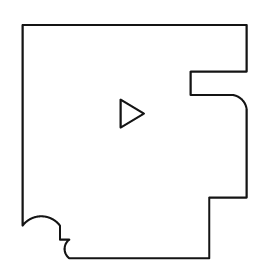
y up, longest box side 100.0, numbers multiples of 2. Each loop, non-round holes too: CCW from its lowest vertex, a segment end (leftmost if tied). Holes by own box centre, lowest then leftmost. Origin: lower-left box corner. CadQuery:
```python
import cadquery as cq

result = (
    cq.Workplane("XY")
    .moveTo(20.0, 0.0)
    .lineTo(80.0, 0.0)
    .lineTo(80.0, 26.0)
    .lineTo(96.0, 26.0)
    .lineTo(96.0, 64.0)
    .threePointArc((94.0, 68.0), (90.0, 70.0))
    .lineTo(72.0, 70.0)
    .lineTo(72.0, 80.0)
    .lineTo(96.0, 80.0)
    .lineTo(96.0, 100.0)
    .lineTo(0.0, 100.0)
    .lineTo(0.0, 14.0)
    .threePointArc((8.0, 18.0), (16.0, 14.0))
    .lineTo(16.0, 8.0)
    .lineTo(20.0, 8.0)
    .threePointArc((18.0, 4.0), (20.0, 0.0))
    .close()
    .moveTo(42.0, 56.0)
    .lineTo(52.0, 62.0)
    .lineTo(42.0, 68.0)
    .close()
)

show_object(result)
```